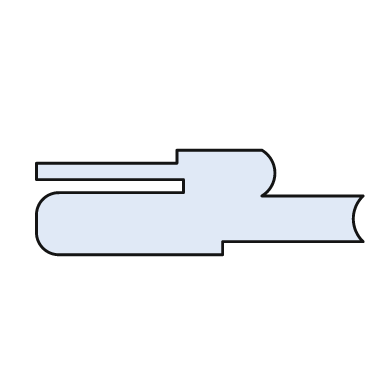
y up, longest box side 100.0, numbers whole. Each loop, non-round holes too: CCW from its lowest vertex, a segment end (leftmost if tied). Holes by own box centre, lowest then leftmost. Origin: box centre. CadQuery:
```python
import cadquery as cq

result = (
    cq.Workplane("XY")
    .moveTo(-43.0, -16.0)
    .lineTo(7.0, -16.0)
    .lineTo(7.0, -12.0)
    .lineTo(50.0, -12.0)
    .threePointArc((47.0, -5.0), (50.0, 2.0))
    .lineTo(19.0, 2.0)
    .threePointArc((23.0, 9.0), (19.0, 16.0))
    .lineTo(-7.0, 16.0)
    .lineTo(-7.0, 12.0)
    .lineTo(-50.0, 12.0)
    .lineTo(-50.0, 7.0)
    .lineTo(-5.0, 7.0)
    .lineTo(-5.0, 3.0)
    .lineTo(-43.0, 3.0)
    .threePointArc((-48.0, 1.0), (-50.0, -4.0))
    .lineTo(-50.0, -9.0)
    .threePointArc((-48.0, -14.0), (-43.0, -16.0))
    .close()
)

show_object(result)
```